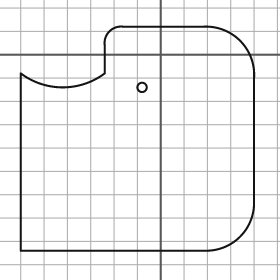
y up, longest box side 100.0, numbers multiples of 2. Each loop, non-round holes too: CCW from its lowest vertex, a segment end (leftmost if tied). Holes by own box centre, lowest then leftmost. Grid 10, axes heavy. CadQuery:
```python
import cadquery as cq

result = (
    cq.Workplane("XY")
    .moveTo(-60.0, -84.0)
    .lineTo(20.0, -84.0)
    .threePointArc((34.0, -78.0), (40.0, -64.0))
    .lineTo(40.0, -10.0)
    .threePointArc((34.0, 6.0), (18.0, 12.0))
    .lineTo(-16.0, 12.0)
    .threePointArc((-22.0, 10.0), (-24.0, 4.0))
    .lineTo(-24.0, -8.0)
    .threePointArc((-42.0, -14.0), (-60.0, -8.0))
    .close()
    .moveTo(-8.0, -14.0)
    .circle(2.0)
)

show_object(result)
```